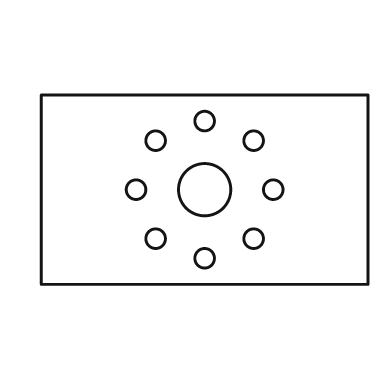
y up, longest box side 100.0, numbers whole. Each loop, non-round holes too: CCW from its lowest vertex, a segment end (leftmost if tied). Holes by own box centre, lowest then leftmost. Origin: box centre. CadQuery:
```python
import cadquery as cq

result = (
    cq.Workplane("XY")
    .moveTo(-50.0, -29.0)
    .lineTo(50.0, -29.0)
    .lineTo(50.0, 29.0)
    .lineTo(-50.0, 29.0)
    .close()
    .moveTo(0.0, -21.0)
    .circle(3.0)
    .moveTo(-15.0, -15.0)
    .circle(3.0)
    .moveTo(15.0, -15.0)
    .circle(3.0)
    .moveTo(-21.0, 0.0)
    .circle(3.0)
    .moveTo(0.0, 0.0)
    .circle(8.0)
    .moveTo(21.0, 0.0)
    .circle(3.0)
    .moveTo(-15.0, 15.0)
    .circle(3.0)
    .moveTo(15.0, 15.0)
    .circle(3.0)
    .moveTo(0.0, 21.0)
    .circle(3.0)
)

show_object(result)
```